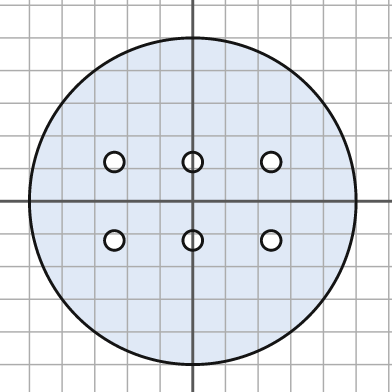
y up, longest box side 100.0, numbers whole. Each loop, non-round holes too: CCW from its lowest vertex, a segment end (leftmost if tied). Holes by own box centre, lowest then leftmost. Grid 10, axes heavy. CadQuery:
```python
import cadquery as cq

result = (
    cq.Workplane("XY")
    .moveTo(0.0, 0.0)
    .circle(50.0)
    .moveTo(-24.0, -12.0)
    .circle(3.0)
    .moveTo(0.0, -12.0)
    .circle(3.0)
    .moveTo(24.0, -12.0)
    .circle(3.0)
    .moveTo(-24.0, 12.0)
    .circle(3.0)
    .moveTo(0.0, 12.0)
    .circle(3.0)
    .moveTo(24.0, 12.0)
    .circle(3.0)
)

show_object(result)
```